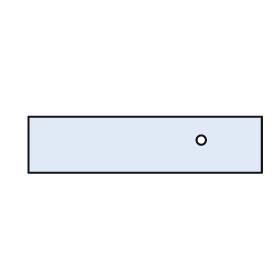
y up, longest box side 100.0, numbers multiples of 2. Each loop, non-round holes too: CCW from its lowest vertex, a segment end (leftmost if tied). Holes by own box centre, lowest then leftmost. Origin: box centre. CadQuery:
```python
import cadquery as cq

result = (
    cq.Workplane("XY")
    .moveTo(-50.0, -12.0)
    .lineTo(50.0, -12.0)
    .lineTo(50.0, 12.0)
    .lineTo(-50.0, 12.0)
    .close()
    .moveTo(24.0, 2.0)
    .circle(2.0)
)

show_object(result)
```